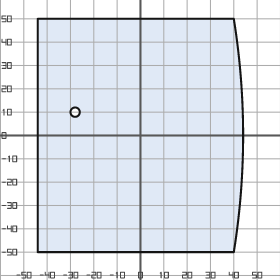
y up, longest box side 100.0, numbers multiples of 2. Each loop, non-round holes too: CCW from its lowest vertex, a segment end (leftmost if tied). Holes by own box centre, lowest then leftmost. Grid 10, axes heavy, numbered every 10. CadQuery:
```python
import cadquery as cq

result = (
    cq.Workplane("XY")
    .moveTo(-44.0, -50.0)
    .lineTo(40.0, -50.0)
    .threePointArc((44.0, 0.0), (40.0, 50.0))
    .lineTo(-44.0, 50.0)
    .close()
    .moveTo(-28.0, 10.0)
    .circle(2.0)
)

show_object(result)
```